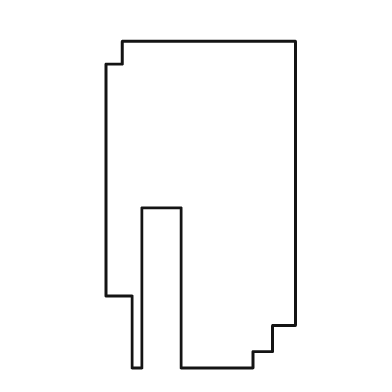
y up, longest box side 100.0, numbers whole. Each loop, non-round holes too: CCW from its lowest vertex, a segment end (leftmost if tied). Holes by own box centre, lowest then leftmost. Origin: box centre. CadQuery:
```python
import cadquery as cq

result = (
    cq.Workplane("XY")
    .moveTo(-21.0, -50.0)
    .lineTo(-18.0, -50.0)
    .lineTo(-18.0, -1.0)
    .lineTo(-6.0, -1.0)
    .lineTo(-6.0, -50.0)
    .lineTo(16.0, -50.0)
    .lineTo(16.0, -45.0)
    .lineTo(22.0, -45.0)
    .lineTo(22.0, -37.0)
    .lineTo(29.0, -37.0)
    .lineTo(29.0, 50.0)
    .lineTo(-24.0, 50.0)
    .lineTo(-24.0, 43.0)
    .lineTo(-29.0, 43.0)
    .lineTo(-29.0, -28.0)
    .lineTo(-21.0, -28.0)
    .close()
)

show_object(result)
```